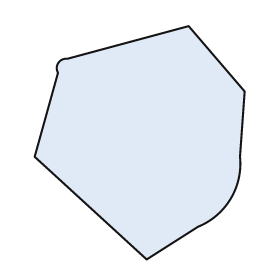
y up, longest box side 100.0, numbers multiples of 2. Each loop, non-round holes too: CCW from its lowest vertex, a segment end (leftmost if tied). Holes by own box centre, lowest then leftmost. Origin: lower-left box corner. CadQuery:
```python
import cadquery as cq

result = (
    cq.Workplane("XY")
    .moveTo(48.0, 0.0)
    .lineTo(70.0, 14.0)
    .threePointArc((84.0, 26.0), (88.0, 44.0))
    .lineTo(90.0, 72.0)
    .lineTo(66.0, 100.0)
    .lineTo(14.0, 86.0)
    .threePointArc((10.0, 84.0), (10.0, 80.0))
    .lineTo(0.0, 44.0)
    .close()
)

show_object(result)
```